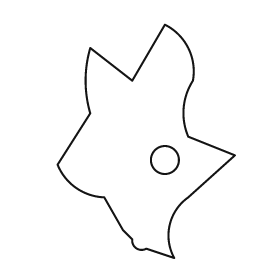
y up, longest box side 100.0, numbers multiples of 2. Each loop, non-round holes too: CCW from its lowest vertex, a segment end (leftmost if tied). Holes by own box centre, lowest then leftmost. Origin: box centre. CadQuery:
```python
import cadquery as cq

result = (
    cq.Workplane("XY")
    .moveTo(12.0, -50.0)
    .threePointArc((10.0, -36.0), (18.0, -24.0))
    .lineTo(38.0, -6.0)
    .lineTo(18.0, 2.0)
    .threePointArc((16.0, 14.0), (20.0, 26.0))
    .threePointArc((18.0, 40.0), (8.0, 50.0))
    .lineTo(-6.0, 26.0)
    .lineTo(-24.0, 40.0)
    .threePointArc((-26.0, 26.0), (-24.0, 12.0))
    .lineTo(-38.0, -10.0)
    .threePointArc((-30.0, -20.0), (-18.0, -24.0))
    .lineTo(-10.0, -38.0)
    .lineTo(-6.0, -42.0)
    .threePointArc((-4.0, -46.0), (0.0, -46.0))
    .close()
    .moveTo(8.0, -8.0)
    .circle(6.0)
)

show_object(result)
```